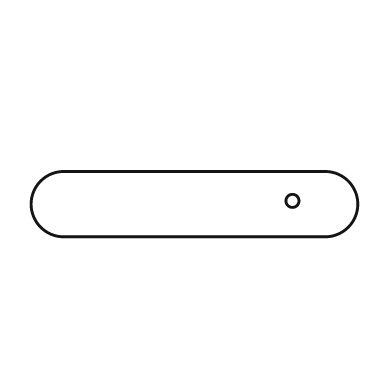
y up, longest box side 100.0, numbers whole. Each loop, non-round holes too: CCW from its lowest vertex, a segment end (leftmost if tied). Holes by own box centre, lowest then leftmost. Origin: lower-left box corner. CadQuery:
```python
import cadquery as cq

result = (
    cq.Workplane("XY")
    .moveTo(10.0, 0.0)
    .lineTo(90.0, 0.0)
    .threePointArc((100.0, 10.0), (90.0, 20.0))
    .lineTo(10.0, 20.0)
    .threePointArc((0.0, 10.0), (10.0, 0.0))
    .close()
    .moveTo(80.0, 11.0)
    .circle(2.0)
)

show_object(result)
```